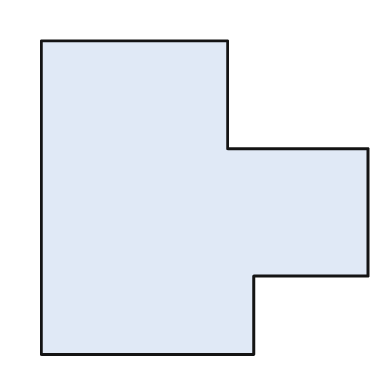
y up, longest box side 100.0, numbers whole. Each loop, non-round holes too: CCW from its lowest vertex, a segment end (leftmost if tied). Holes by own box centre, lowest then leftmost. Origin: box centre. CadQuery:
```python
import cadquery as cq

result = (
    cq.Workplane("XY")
    .moveTo(-50.0, -48.0)
    .lineTo(15.0, -48.0)
    .lineTo(15.0, -24.0)
    .lineTo(50.0, -24.0)
    .lineTo(50.0, 15.0)
    .lineTo(7.0, 15.0)
    .lineTo(7.0, 48.0)
    .lineTo(-50.0, 48.0)
    .close()
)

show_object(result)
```